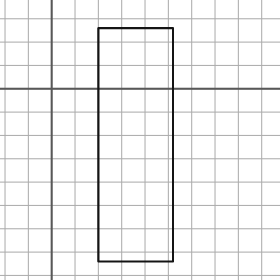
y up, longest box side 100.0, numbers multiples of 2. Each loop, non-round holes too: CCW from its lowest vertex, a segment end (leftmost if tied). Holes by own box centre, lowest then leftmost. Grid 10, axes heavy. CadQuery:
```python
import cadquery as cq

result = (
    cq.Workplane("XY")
    .moveTo(20.0, -74.0)
    .lineTo(52.0, -74.0)
    .lineTo(52.0, 26.0)
    .lineTo(20.0, 26.0)
    .close()
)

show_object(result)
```